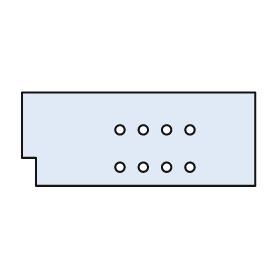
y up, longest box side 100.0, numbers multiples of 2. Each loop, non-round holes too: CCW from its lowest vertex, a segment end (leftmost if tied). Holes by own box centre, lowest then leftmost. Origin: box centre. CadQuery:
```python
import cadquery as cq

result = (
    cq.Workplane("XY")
    .moveTo(-44.0, -20.0)
    .lineTo(50.0, -20.0)
    .lineTo(50.0, 20.0)
    .lineTo(-50.0, 20.0)
    .lineTo(-50.0, -8.0)
    .lineTo(-44.0, -8.0)
    .close()
    .moveTo(-8.0, -12.0)
    .circle(2.0)
    .moveTo(2.0, -12.0)
    .circle(2.0)
    .moveTo(12.0, -12.0)
    .circle(2.0)
    .moveTo(22.0, -12.0)
    .circle(2.0)
    .moveTo(-8.0, 4.0)
    .circle(2.0)
    .moveTo(2.0, 4.0)
    .circle(2.0)
    .moveTo(12.0, 4.0)
    .circle(2.0)
    .moveTo(22.0, 4.0)
    .circle(2.0)
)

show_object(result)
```